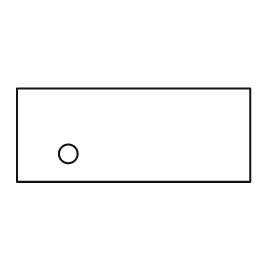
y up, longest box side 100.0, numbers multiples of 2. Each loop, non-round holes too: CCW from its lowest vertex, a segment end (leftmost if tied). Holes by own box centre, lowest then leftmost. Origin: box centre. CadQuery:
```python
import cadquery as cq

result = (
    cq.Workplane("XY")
    .moveTo(-50.0, -20.0)
    .lineTo(50.0, -20.0)
    .lineTo(50.0, 20.0)
    .lineTo(-50.0, 20.0)
    .close()
    .moveTo(-28.0, -8.0)
    .circle(4.0)
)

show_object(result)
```